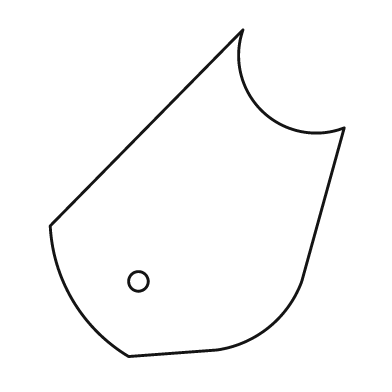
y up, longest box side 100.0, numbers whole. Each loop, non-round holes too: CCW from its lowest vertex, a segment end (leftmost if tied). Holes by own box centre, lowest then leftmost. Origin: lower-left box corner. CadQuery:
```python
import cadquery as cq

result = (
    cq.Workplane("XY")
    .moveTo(24.0, 0.0)
    .lineTo(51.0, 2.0)
    .threePointArc((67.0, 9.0), (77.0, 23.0))
    .lineTo(90.0, 70.0)
    .threePointArc((65.0, 75.0), (59.0, 100.0))
    .lineTo(0.0, 40.0)
    .threePointArc((7.0, 17.0), (24.0, 0.0))
    .close()
    .moveTo(27.0, 23.0)
    .circle(3.0)
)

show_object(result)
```